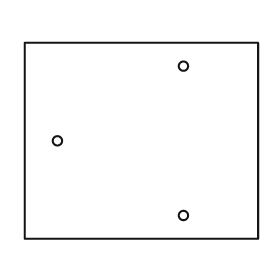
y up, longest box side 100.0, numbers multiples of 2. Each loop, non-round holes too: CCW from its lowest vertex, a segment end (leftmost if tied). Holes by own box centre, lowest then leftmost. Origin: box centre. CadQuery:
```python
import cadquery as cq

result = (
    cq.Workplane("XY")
    .moveTo(-50.0, -42.0)
    .lineTo(50.0, -42.0)
    .lineTo(50.0, 42.0)
    .lineTo(-50.0, 42.0)
    .close()
    .moveTo(18.0, -32.0)
    .circle(2.0)
    .moveTo(-36.0, 0.0)
    .circle(2.0)
    .moveTo(18.0, 32.0)
    .circle(2.0)
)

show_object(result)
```